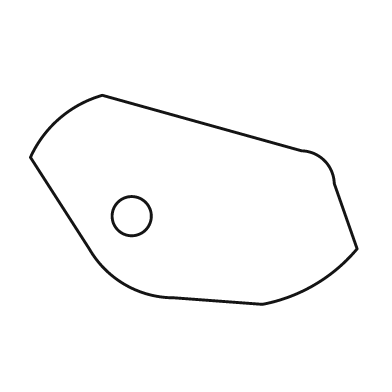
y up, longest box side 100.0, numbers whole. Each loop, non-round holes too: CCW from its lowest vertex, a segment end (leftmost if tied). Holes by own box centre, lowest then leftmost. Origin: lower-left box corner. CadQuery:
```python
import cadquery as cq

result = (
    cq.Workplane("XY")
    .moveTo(71.0, 0.0)
    .threePointArc((87.0, 6.0), (100.0, 17.0))
    .lineTo(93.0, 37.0)
    .threePointArc((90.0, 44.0), (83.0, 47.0))
    .lineTo(22.0, 64.0)
    .threePointArc((9.0, 57.0), (0.0, 45.0))
    .lineTo(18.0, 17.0)
    .threePointArc((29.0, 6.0), (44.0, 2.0))
    .close()
    .moveTo(31.0, 27.0)
    .circle(6.0)
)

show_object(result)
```